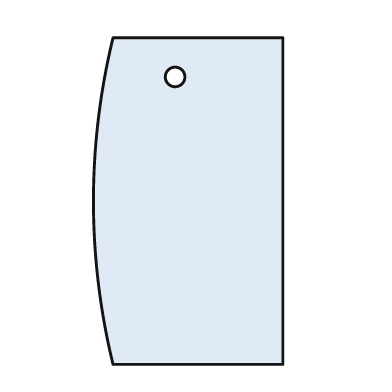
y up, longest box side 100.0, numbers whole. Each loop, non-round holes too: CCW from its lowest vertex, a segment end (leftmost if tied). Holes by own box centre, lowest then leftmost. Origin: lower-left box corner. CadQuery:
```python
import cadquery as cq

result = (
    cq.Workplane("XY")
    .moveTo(6.0, 0.0)
    .lineTo(58.0, 0.0)
    .lineTo(58.0, 100.0)
    .lineTo(6.0, 100.0)
    .threePointArc((0.0, 50.0), (6.0, 0.0))
    .close()
    .moveTo(25.0, 88.0)
    .circle(3.0)
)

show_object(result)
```